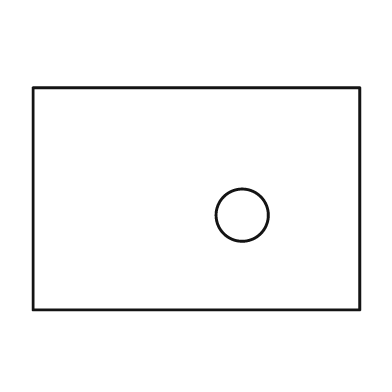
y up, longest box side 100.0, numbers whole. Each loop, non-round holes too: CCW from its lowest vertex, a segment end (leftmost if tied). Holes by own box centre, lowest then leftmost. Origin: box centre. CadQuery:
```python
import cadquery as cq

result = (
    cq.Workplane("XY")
    .moveTo(-50.0, -34.0)
    .lineTo(50.0, -34.0)
    .lineTo(50.0, 34.0)
    .lineTo(-50.0, 34.0)
    .close()
    .moveTo(14.0, -5.0)
    .circle(8.0)
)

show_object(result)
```